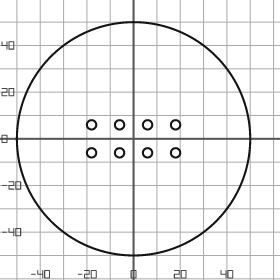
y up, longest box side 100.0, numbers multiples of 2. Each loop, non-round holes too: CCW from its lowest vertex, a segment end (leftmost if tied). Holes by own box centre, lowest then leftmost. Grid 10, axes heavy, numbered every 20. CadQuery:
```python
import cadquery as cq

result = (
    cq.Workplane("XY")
    .moveTo(0.0, 0.0)
    .circle(50.0)
    .moveTo(-18.0, -6.0)
    .circle(2.0)
    .moveTo(-6.0, -6.0)
    .circle(2.0)
    .moveTo(6.0, -6.0)
    .circle(2.0)
    .moveTo(18.0, -6.0)
    .circle(2.0)
    .moveTo(-18.0, 6.0)
    .circle(2.0)
    .moveTo(-6.0, 6.0)
    .circle(2.0)
    .moveTo(6.0, 6.0)
    .circle(2.0)
    .moveTo(18.0, 6.0)
    .circle(2.0)
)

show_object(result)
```